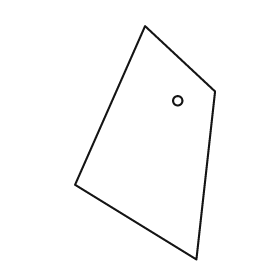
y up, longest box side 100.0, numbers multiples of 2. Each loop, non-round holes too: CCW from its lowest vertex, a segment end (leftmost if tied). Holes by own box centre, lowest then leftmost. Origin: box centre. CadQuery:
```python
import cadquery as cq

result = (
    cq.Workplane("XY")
    .moveTo(22.0, -50.0)
    .lineTo(30.0, 22.0)
    .lineTo(0.0, 50.0)
    .lineTo(-30.0, -18.0)
    .close()
    .moveTo(14.0, 18.0)
    .circle(2.0)
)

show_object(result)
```